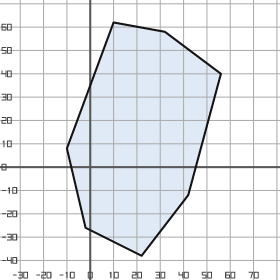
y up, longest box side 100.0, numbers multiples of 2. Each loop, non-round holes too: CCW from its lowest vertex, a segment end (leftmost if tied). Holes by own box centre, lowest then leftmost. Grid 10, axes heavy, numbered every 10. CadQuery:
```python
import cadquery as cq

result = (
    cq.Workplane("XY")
    .moveTo(22.0, -38.0)
    .lineTo(42.0, -12.0)
    .lineTo(56.0, 40.0)
    .lineTo(32.0, 58.0)
    .lineTo(10.0, 62.0)
    .lineTo(-10.0, 8.0)
    .lineTo(-2.0, -26.0)
    .close()
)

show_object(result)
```